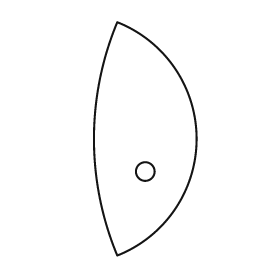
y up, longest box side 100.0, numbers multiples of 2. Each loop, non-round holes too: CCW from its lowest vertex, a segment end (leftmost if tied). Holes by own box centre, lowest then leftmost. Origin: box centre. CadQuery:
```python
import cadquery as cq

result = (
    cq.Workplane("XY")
    .moveTo(-12.0, -50.0)
    .threePointArc((22.0, 0.0), (-12.0, 50.0))
    .threePointArc((-22.0, 0.0), (-12.0, -50.0))
    .close()
    .moveTo(0.0, -14.0)
    .circle(4.0)
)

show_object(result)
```